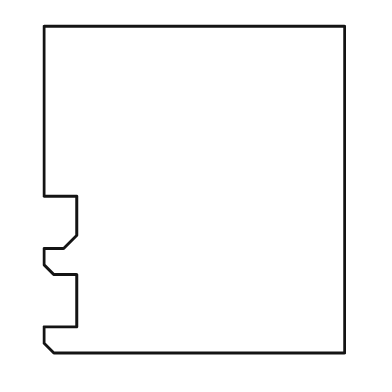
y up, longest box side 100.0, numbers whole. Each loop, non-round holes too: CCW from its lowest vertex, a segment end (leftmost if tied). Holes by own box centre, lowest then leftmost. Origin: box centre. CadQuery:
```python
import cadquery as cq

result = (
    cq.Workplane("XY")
    .moveTo(-43.0, -50.0)
    .lineTo(46.0, -50.0)
    .lineTo(46.0, 50.0)
    .lineTo(-46.0, 50.0)
    .lineTo(-46.0, -2.0)
    .lineTo(-36.0, -2.0)
    .lineTo(-36.0, -14.0)
    .lineTo(-40.0, -18.0)
    .lineTo(-46.0, -18.0)
    .lineTo(-46.0, -23.0)
    .lineTo(-43.0, -26.0)
    .lineTo(-36.0, -26.0)
    .lineTo(-36.0, -42.0)
    .lineTo(-46.0, -42.0)
    .lineTo(-46.0, -47.0)
    .close()
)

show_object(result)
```